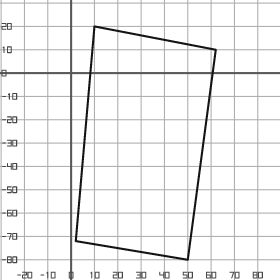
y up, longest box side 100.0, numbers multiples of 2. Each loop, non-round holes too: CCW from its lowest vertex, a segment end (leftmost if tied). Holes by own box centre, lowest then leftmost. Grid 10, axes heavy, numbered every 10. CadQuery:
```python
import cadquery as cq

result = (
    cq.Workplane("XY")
    .moveTo(50.0, -80.0)
    .lineTo(62.0, 10.0)
    .lineTo(10.0, 20.0)
    .lineTo(2.0, -72.0)
    .close()
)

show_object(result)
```